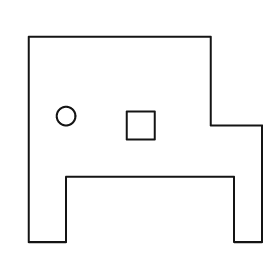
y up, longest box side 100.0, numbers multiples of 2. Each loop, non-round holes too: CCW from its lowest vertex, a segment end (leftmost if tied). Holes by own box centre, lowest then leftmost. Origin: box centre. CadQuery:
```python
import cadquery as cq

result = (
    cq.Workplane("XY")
    .moveTo(-50.0, -44.0)
    .lineTo(-34.0, -44.0)
    .lineTo(-34.0, -16.0)
    .lineTo(38.0, -16.0)
    .lineTo(38.0, -44.0)
    .lineTo(50.0, -44.0)
    .lineTo(50.0, 6.0)
    .lineTo(28.0, 6.0)
    .lineTo(28.0, 44.0)
    .lineTo(-50.0, 44.0)
    .close()
    .moveTo(-8.0, 0.0)
    .lineTo(4.0, 0.0)
    .lineTo(4.0, 12.0)
    .lineTo(-8.0, 12.0)
    .close()
    .moveTo(-34.0, 10.0)
    .circle(4.0)
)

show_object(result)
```